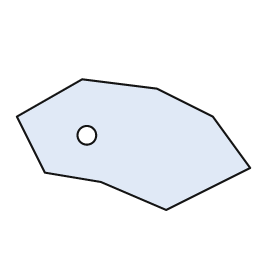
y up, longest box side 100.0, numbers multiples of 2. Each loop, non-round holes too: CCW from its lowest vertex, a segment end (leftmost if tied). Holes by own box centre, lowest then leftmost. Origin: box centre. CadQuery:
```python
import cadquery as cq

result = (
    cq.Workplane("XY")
    .moveTo(14.0, -28.0)
    .lineTo(50.0, -10.0)
    .lineTo(34.0, 12.0)
    .lineTo(10.0, 24.0)
    .lineTo(-22.0, 28.0)
    .lineTo(-50.0, 12.0)
    .lineTo(-38.0, -12.0)
    .lineTo(-14.0, -16.0)
    .close()
    .moveTo(-20.0, 4.0)
    .circle(4.0)
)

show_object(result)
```